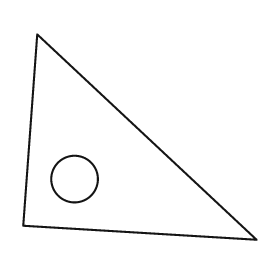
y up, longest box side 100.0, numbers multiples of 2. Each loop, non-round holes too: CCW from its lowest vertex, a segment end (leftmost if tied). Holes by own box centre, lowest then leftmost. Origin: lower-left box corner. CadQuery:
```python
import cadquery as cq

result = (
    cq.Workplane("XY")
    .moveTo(100.0, 0.0)
    .lineTo(6.0, 88.0)
    .lineTo(0.0, 6.0)
    .close()
    .moveTo(22.0, 26.0)
    .circle(10.0)
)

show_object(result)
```